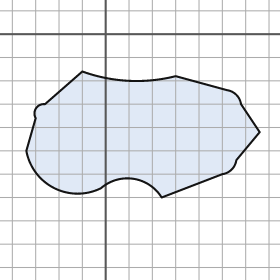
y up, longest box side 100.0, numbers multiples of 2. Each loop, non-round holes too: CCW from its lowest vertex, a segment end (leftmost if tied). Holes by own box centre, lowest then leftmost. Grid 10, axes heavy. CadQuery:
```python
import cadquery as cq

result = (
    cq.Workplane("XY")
    .moveTo(24.0, -70.0)
    .lineTo(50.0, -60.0)
    .threePointArc((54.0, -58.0), (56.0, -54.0))
    .lineTo(66.0, -42.0)
    .lineTo(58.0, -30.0)
    .threePointArc((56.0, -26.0), (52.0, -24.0))
    .lineTo(30.0, -18.0)
    .threePointArc((10.0, -20.0), (-10.0, -16.0))
    .lineTo(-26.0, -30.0)
    .threePointArc((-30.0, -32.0), (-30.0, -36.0))
    .lineTo(-34.0, -50.0)
    .threePointArc((-22.0, -66.0), (-2.0, -66.0))
    .threePointArc((12.0, -62.0), (24.0, -70.0))
    .close()
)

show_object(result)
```